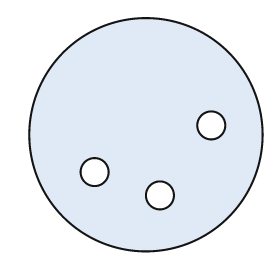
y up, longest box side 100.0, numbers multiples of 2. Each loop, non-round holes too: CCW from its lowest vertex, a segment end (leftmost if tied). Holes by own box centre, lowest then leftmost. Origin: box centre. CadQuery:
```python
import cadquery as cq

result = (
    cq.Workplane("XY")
    .moveTo(0.0, 0.0)
    .circle(50.0)
    .moveTo(6.0, -26.0)
    .circle(6.0)
    .moveTo(-22.0, -16.0)
    .circle(6.0)
    .moveTo(28.0, 4.0)
    .circle(6.0)
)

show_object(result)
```